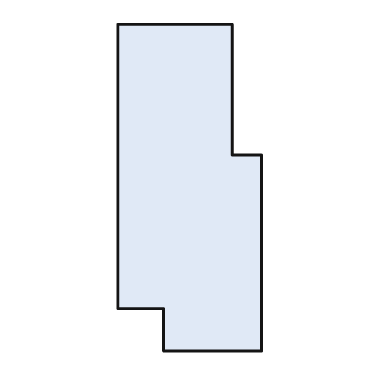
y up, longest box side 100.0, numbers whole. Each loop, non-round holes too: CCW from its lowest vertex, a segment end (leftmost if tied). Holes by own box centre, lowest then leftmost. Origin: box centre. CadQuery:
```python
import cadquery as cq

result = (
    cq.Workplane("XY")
    .moveTo(-8.0, -50.0)
    .lineTo(22.0, -50.0)
    .lineTo(22.0, 10.0)
    .lineTo(13.0, 10.0)
    .lineTo(13.0, 50.0)
    .lineTo(-22.0, 50.0)
    .lineTo(-22.0, -37.0)
    .lineTo(-8.0, -37.0)
    .close()
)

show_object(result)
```